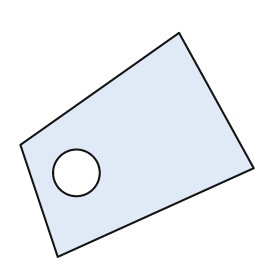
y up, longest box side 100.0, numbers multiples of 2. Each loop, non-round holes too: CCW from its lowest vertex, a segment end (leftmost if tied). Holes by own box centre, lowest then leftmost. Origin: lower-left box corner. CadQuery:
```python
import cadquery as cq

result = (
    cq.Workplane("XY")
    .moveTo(16.0, 0.0)
    .lineTo(100.0, 38.0)
    .lineTo(68.0, 96.0)
    .lineTo(0.0, 48.0)
    .close()
    .moveTo(24.0, 36.0)
    .circle(10.0)
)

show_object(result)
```